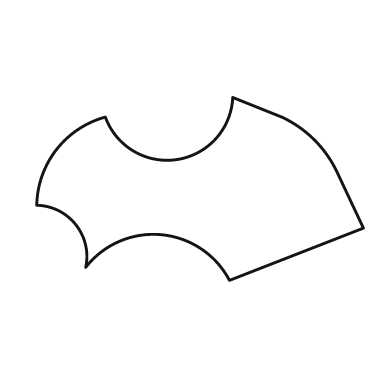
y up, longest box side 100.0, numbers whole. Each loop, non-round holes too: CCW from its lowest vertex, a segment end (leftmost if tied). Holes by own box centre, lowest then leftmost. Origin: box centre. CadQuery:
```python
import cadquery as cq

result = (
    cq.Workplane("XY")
    .moveTo(9.0, -28.0)
    .lineTo(50.0, -12.0)
    .lineTo(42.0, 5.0)
    .threePointArc((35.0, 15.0), (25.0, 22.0))
    .lineTo(10.0, 28.0)
    .threePointArc((-7.0, 9.0), (-29.0, 22.0))
    .threePointArc((-44.0, 12.0), (-50.0, -5.0))
    .threePointArc((-38.0, -11.0), (-35.0, -24.0))
    .threePointArc((-12.0, -14.0), (9.0, -28.0))
    .close()
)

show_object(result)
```